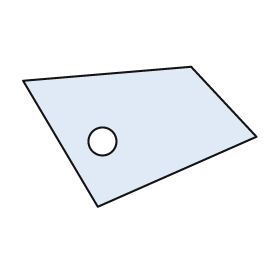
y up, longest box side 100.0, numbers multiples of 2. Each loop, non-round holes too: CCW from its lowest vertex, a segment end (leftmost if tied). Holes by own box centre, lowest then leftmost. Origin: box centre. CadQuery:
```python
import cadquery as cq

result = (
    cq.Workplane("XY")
    .moveTo(-18.0, -30.0)
    .lineTo(50.0, 0.0)
    .lineTo(22.0, 30.0)
    .lineTo(-50.0, 24.0)
    .close()
    .moveTo(-16.0, -2.0)
    .circle(6.0)
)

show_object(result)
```